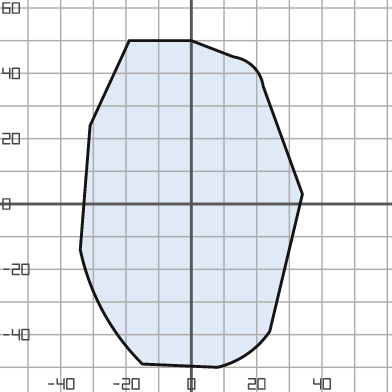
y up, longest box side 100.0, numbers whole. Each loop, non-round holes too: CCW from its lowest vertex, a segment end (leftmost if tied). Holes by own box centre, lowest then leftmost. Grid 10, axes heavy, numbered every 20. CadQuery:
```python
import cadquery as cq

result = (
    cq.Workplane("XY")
    .moveTo(8.0, -50.0)
    .threePointArc((17.0, -46.0), (24.0, -39.0))
    .lineTo(34.0, 3.0)
    .lineTo(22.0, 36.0)
    .threePointArc((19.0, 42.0), (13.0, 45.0))
    .lineTo(0.0, 50.0)
    .lineTo(-19.0, 50.0)
    .lineTo(-31.0, 24.0)
    .lineTo(-34.0, -14.0)
    .threePointArc((-27.0, -33.0), (-15.0, -49.0))
    .close()
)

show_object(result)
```